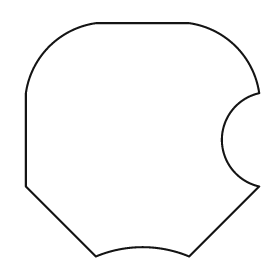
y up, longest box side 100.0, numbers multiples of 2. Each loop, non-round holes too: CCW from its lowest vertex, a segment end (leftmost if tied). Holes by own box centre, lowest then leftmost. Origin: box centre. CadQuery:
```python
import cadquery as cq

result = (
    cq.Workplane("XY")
    .moveTo(-20.0, -50.0)
    .threePointArc((0.0, -46.0), (20.0, -50.0))
    .lineTo(50.0, -20.0)
    .threePointArc((34.0, 0.0), (50.0, 20.0))
    .threePointArc((40.0, 40.0), (20.0, 50.0))
    .lineTo(-20.0, 50.0)
    .threePointArc((-40.0, 40.0), (-50.0, 20.0))
    .lineTo(-50.0, -20.0)
    .close()
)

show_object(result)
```